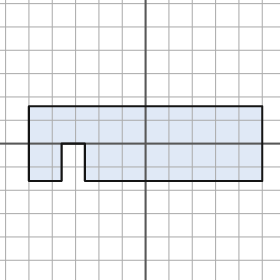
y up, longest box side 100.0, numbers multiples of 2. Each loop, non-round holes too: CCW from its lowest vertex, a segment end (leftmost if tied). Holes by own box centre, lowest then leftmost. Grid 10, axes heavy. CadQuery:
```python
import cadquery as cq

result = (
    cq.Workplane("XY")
    .moveTo(-50.0, -16.0)
    .lineTo(-36.0, -16.0)
    .lineTo(-36.0, 0.0)
    .lineTo(-26.0, 0.0)
    .lineTo(-26.0, -16.0)
    .lineTo(50.0, -16.0)
    .lineTo(50.0, 16.0)
    .lineTo(-50.0, 16.0)
    .close()
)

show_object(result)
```